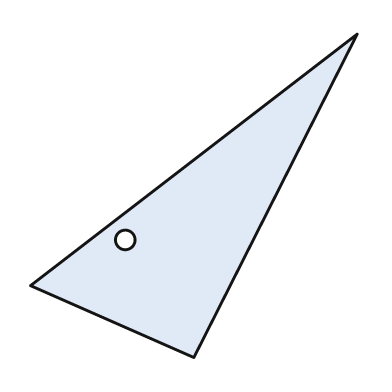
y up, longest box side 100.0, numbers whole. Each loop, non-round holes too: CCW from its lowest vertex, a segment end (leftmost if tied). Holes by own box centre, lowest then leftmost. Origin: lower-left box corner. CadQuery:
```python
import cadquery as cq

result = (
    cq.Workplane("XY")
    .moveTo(50.0, 0.0)
    .lineTo(100.0, 99.0)
    .lineTo(0.0, 22.0)
    .close()
    .moveTo(29.0, 36.0)
    .circle(3.0)
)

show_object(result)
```